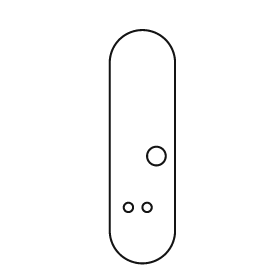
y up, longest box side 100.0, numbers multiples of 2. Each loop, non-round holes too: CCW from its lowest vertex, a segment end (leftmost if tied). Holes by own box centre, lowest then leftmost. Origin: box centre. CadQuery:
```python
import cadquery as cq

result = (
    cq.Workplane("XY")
    .moveTo(-14.0, -36.0)
    .threePointArc((0.0, -50.0), (14.0, -36.0))
    .lineTo(14.0, 36.0)
    .threePointArc((0.0, 50.0), (-14.0, 36.0))
    .close()
    .moveTo(-6.0, -26.0)
    .circle(2.0)
    .moveTo(2.0, -26.0)
    .circle(2.0)
    .moveTo(6.0, -4.0)
    .circle(4.0)
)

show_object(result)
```